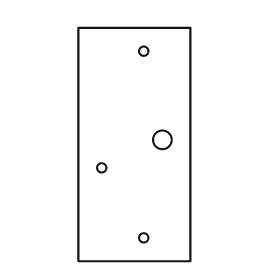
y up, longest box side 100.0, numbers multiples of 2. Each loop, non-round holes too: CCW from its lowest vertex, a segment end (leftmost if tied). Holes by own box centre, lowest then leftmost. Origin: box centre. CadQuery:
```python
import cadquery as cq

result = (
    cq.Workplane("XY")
    .moveTo(-24.0, -50.0)
    .lineTo(24.0, -50.0)
    .lineTo(24.0, 50.0)
    .lineTo(-24.0, 50.0)
    .close()
    .moveTo(4.0, -40.0)
    .circle(2.0)
    .moveTo(-14.0, -10.0)
    .circle(2.0)
    .moveTo(12.0, 2.0)
    .circle(4.0)
    .moveTo(4.0, 40.0)
    .circle(2.0)
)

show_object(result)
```